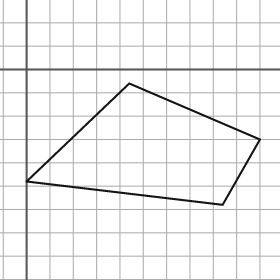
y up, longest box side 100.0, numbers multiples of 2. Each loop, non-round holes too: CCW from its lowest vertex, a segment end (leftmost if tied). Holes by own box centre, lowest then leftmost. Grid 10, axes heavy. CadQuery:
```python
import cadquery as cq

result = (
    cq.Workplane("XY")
    .moveTo(84.0, -58.0)
    .lineTo(100.0, -30.0)
    .lineTo(44.0, -6.0)
    .lineTo(0.0, -48.0)
    .close()
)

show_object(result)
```